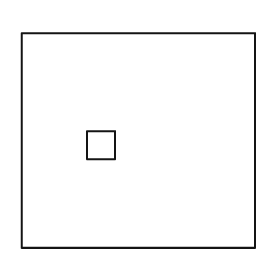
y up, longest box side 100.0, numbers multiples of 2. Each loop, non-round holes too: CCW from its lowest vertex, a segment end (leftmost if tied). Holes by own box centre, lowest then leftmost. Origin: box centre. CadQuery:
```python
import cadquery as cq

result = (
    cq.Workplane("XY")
    .moveTo(-50.0, -46.0)
    .lineTo(50.0, -46.0)
    .lineTo(50.0, 46.0)
    .lineTo(-50.0, 46.0)
    .close()
    .moveTo(-22.0, -8.0)
    .lineTo(-10.0, -8.0)
    .lineTo(-10.0, 4.0)
    .lineTo(-22.0, 4.0)
    .close()
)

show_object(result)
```